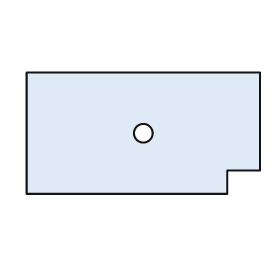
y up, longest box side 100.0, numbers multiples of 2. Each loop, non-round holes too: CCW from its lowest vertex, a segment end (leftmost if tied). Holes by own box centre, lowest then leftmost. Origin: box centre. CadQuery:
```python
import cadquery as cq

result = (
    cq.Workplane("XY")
    .moveTo(-50.0, -26.0)
    .lineTo(36.0, -26.0)
    .lineTo(36.0, -16.0)
    .lineTo(50.0, -16.0)
    .lineTo(50.0, 26.0)
    .lineTo(-50.0, 26.0)
    .close()
    .moveTo(0.0, 0.0)
    .circle(4.0)
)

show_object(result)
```